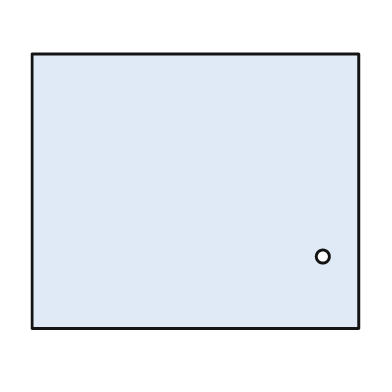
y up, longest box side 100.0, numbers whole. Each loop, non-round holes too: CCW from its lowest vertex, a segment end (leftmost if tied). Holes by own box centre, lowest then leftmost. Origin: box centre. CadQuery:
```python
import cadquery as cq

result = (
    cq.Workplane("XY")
    .moveTo(-50.0, -42.0)
    .lineTo(50.0, -42.0)
    .lineTo(50.0, 42.0)
    .lineTo(-50.0, 42.0)
    .close()
    .moveTo(39.0, -20.0)
    .circle(2.0)
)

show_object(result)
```